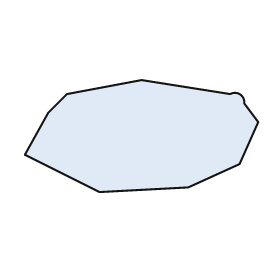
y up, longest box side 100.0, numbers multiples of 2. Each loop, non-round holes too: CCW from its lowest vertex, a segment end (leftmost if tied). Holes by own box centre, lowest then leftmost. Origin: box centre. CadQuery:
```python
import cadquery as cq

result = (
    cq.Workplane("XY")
    .moveTo(-18.0, -24.0)
    .lineTo(20.0, -22.0)
    .lineTo(42.0, -12.0)
    .lineTo(50.0, 6.0)
    .lineTo(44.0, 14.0)
    .threePointArc((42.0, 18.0), (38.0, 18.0))
    .lineTo(0.0, 24.0)
    .lineTo(-32.0, 18.0)
    .lineTo(-40.0, 10.0)
    .lineTo(-50.0, -8.0)
    .close()
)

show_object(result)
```